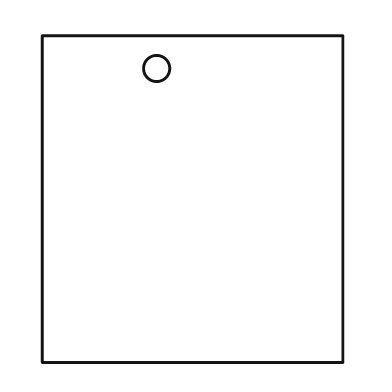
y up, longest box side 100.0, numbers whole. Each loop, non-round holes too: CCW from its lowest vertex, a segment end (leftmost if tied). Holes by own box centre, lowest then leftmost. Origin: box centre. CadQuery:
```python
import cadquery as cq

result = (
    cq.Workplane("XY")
    .moveTo(-46.0, -50.0)
    .lineTo(46.0, -50.0)
    .lineTo(46.0, 50.0)
    .lineTo(-46.0, 50.0)
    .close()
    .moveTo(-11.0, 40.0)
    .circle(4.0)
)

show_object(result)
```